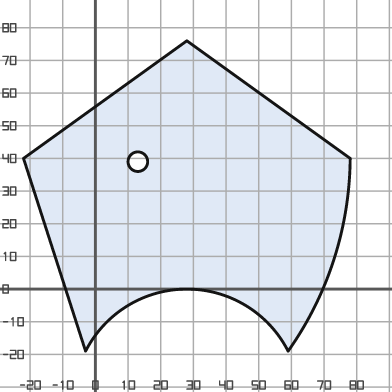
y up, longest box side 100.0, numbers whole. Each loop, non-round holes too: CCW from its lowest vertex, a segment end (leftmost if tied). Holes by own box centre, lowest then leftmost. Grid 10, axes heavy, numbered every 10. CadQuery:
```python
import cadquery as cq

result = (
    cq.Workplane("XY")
    .moveTo(-3.0, -19.0)
    .threePointArc((28.0, 0.0), (59.0, -19.0))
    .threePointArc((73.0, 9.0), (78.0, 40.0))
    .lineTo(28.0, 76.0)
    .lineTo(-22.0, 40.0)
    .close()
    .moveTo(13.0, 39.0)
    .circle(3.0)
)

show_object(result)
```